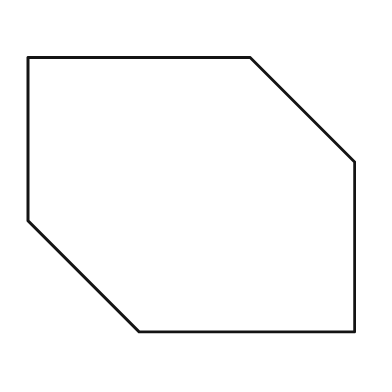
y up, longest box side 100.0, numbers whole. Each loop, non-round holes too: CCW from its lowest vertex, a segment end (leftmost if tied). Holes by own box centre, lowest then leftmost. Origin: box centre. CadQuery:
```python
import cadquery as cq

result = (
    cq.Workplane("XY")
    .moveTo(-16.0, -42.0)
    .lineTo(50.0, -42.0)
    .lineTo(50.0, 10.0)
    .lineTo(18.0, 42.0)
    .lineTo(-50.0, 42.0)
    .lineTo(-50.0, -8.0)
    .close()
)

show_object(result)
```